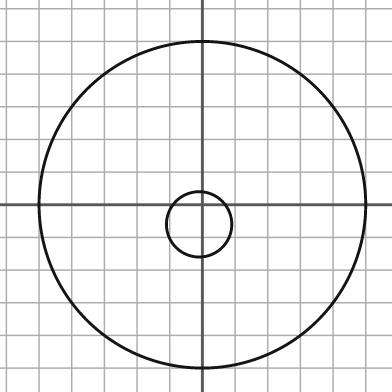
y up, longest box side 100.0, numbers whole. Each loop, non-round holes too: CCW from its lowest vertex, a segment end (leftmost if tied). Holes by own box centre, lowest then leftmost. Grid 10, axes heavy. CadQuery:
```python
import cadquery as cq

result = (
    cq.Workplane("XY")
    .moveTo(0.0, 0.0)
    .circle(50.0)
    .moveTo(-1.0, -6.0)
    .circle(10.0)
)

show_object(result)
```